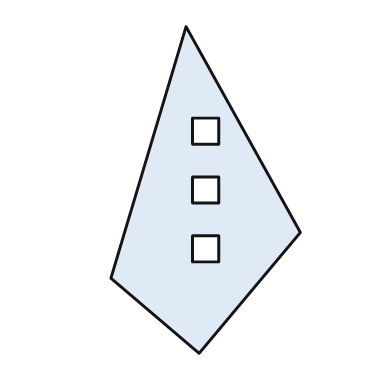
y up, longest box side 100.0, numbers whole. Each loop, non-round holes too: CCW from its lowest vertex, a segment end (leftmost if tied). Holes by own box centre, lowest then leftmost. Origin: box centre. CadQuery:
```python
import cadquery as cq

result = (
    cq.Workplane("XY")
    .moveTo(-2.0, -50.0)
    .lineTo(29.0, -13.0)
    .lineTo(-6.0, 50.0)
    .lineTo(-29.0, -27.0)
    .close()
    .moveTo(-4.0, -22.0)
    .lineTo(4.0, -22.0)
    .lineTo(4.0, -14.0)
    .lineTo(-4.0, -14.0)
    .close()
    .moveTo(-4.0, -4.0)
    .lineTo(4.0, -4.0)
    .lineTo(4.0, 4.0)
    .lineTo(-4.0, 4.0)
    .close()
    .moveTo(-4.0, 14.0)
    .lineTo(4.0, 14.0)
    .lineTo(4.0, 22.0)
    .lineTo(-4.0, 22.0)
    .close()
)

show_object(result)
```